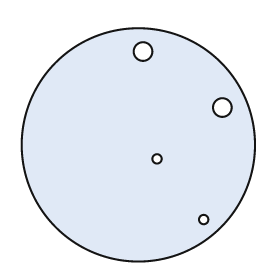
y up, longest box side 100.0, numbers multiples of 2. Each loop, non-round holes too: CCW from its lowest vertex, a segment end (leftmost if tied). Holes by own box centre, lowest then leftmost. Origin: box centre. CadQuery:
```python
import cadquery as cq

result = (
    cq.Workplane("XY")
    .moveTo(0.0, 0.0)
    .circle(50.0)
    .moveTo(28.0, -32.0)
    .circle(2.0)
    .moveTo(8.0, -6.0)
    .circle(2.0)
    .moveTo(36.0, 16.0)
    .circle(4.0)
    .moveTo(2.0, 40.0)
    .circle(4.0)
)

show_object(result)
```